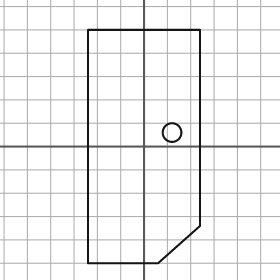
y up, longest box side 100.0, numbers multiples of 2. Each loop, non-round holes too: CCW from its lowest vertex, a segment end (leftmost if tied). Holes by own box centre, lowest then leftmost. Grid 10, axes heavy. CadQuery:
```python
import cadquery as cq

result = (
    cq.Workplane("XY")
    .moveTo(-24.0, -50.0)
    .lineTo(6.0, -50.0)
    .lineTo(24.0, -34.0)
    .lineTo(24.0, 50.0)
    .lineTo(-24.0, 50.0)
    .close()
    .moveTo(12.0, 6.0)
    .circle(4.0)
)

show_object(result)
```